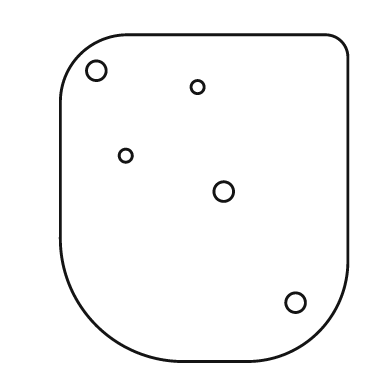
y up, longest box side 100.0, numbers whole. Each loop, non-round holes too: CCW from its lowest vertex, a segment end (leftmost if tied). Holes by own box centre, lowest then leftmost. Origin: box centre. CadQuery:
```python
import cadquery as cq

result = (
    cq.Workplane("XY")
    .moveTo(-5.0, -50.0)
    .lineTo(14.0, -50.0)
    .threePointArc((35.0, -41.0), (44.0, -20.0))
    .lineTo(44.0, 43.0)
    .threePointArc((42.0, 48.0), (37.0, 50.0))
    .lineTo(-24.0, 50.0)
    .threePointArc((-38.0, 44.0), (-44.0, 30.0))
    .lineTo(-44.0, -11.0)
    .threePointArc((-33.0, -39.0), (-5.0, -50.0))
    .close()
    .moveTo(28.0, -32.0)
    .circle(3.0)
    .moveTo(6.0, 2.0)
    .circle(3.0)
    .moveTo(-24.0, 13.0)
    .circle(2.0)
    .moveTo(-2.0, 34.0)
    .circle(2.0)
    .moveTo(-33.0, 39.0)
    .circle(3.0)
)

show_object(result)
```